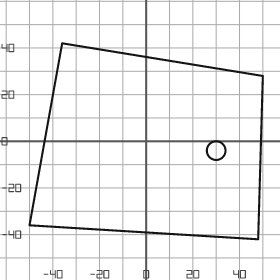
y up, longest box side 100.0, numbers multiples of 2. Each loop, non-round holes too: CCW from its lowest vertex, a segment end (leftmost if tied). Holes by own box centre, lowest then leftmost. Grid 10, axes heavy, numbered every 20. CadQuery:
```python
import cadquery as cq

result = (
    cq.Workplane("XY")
    .moveTo(48.0, -42.0)
    .lineTo(50.0, 28.0)
    .lineTo(-36.0, 42.0)
    .lineTo(-50.0, -36.0)
    .close()
    .moveTo(30.0, -4.0)
    .circle(4.0)
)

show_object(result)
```